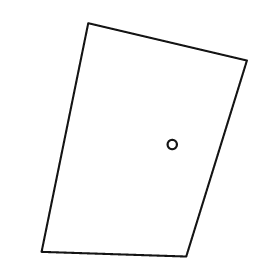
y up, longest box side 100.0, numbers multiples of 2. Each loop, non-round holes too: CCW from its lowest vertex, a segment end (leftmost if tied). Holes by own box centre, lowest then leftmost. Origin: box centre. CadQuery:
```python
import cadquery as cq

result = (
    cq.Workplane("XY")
    .moveTo(18.0, -50.0)
    .lineTo(44.0, 34.0)
    .lineTo(-24.0, 50.0)
    .lineTo(-44.0, -48.0)
    .close()
    .moveTo(12.0, -2.0)
    .circle(2.0)
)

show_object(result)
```